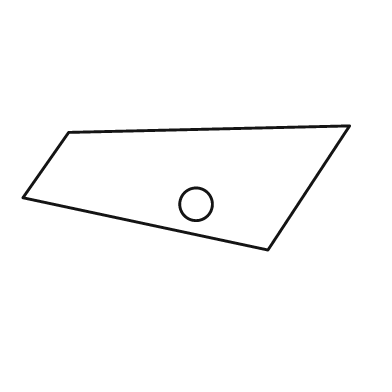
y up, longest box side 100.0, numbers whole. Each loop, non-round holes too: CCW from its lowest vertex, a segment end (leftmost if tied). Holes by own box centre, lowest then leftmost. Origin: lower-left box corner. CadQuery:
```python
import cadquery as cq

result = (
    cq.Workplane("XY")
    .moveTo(75.0, 0.0)
    .lineTo(100.0, 38.0)
    .lineTo(14.0, 36.0)
    .lineTo(0.0, 16.0)
    .close()
    .moveTo(53.0, 14.0)
    .circle(5.0)
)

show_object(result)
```